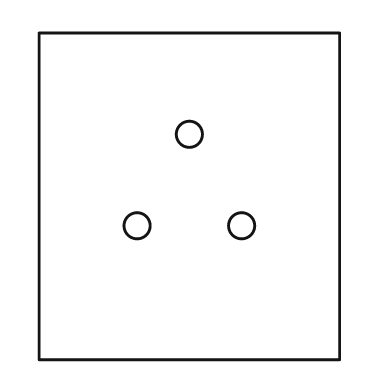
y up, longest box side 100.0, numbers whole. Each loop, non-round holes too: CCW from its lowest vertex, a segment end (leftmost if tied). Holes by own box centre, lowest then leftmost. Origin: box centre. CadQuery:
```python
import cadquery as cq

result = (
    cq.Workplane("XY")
    .moveTo(-46.0, -50.0)
    .lineTo(46.0, -50.0)
    .lineTo(46.0, 50.0)
    .lineTo(-46.0, 50.0)
    .close()
    .moveTo(-16.0, -9.0)
    .circle(4.0)
    .moveTo(16.0, -9.0)
    .circle(4.0)
    .moveTo(0.0, 19.0)
    .circle(4.0)
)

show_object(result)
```